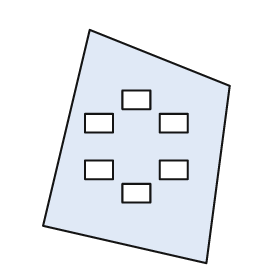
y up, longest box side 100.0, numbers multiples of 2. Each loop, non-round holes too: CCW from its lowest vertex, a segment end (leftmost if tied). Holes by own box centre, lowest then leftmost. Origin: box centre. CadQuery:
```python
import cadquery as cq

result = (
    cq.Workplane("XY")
    .moveTo(30.0, -50.0)
    .lineTo(40.0, 26.0)
    .lineTo(-20.0, 50.0)
    .lineTo(-40.0, -34.0)
    .close()
    .moveTo(-6.0, -24.0)
    .lineTo(6.0, -24.0)
    .lineTo(6.0, -16.0)
    .lineTo(-6.0, -16.0)
    .close()
    .moveTo(-22.0, -14.0)
    .lineTo(-10.0, -14.0)
    .lineTo(-10.0, -6.0)
    .lineTo(-22.0, -6.0)
    .close()
    .moveTo(10.0, -14.0)
    .lineTo(22.0, -14.0)
    .lineTo(22.0, -6.0)
    .lineTo(10.0, -6.0)
    .close()
    .moveTo(-22.0, 6.0)
    .lineTo(-10.0, 6.0)
    .lineTo(-10.0, 14.0)
    .lineTo(-22.0, 14.0)
    .close()
    .moveTo(10.0, 6.0)
    .lineTo(22.0, 6.0)
    .lineTo(22.0, 14.0)
    .lineTo(10.0, 14.0)
    .close()
    .moveTo(-6.0, 16.0)
    .lineTo(6.0, 16.0)
    .lineTo(6.0, 24.0)
    .lineTo(-6.0, 24.0)
    .close()
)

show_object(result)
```